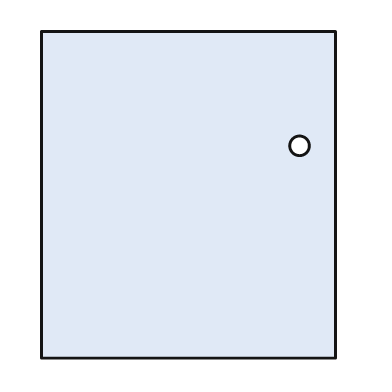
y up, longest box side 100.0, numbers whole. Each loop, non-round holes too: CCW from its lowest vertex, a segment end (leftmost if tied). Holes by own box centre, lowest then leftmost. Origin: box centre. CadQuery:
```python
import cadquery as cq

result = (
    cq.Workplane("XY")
    .moveTo(-45.0, -50.0)
    .lineTo(45.0, -50.0)
    .lineTo(45.0, 50.0)
    .lineTo(-45.0, 50.0)
    .close()
    .moveTo(34.0, 15.0)
    .circle(3.0)
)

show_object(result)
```